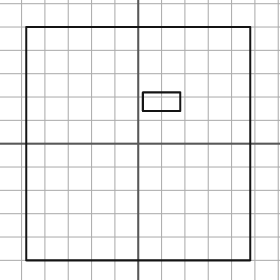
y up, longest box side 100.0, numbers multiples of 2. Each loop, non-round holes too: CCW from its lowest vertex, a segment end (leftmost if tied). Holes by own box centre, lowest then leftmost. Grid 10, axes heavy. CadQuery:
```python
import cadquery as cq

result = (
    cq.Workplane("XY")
    .moveTo(-48.0, -50.0)
    .lineTo(48.0, -50.0)
    .lineTo(48.0, 50.0)
    .lineTo(-48.0, 50.0)
    .close()
    .moveTo(2.0, 14.0)
    .lineTo(18.0, 14.0)
    .lineTo(18.0, 22.0)
    .lineTo(2.0, 22.0)
    .close()
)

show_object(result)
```